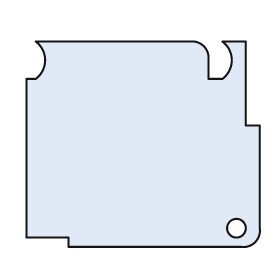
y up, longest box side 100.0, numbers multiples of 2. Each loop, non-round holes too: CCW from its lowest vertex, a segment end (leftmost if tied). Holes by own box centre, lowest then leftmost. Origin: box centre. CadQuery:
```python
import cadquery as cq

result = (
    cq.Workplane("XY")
    .moveTo(-32.0, -44.0)
    .lineTo(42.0, -44.0)
    .threePointArc((48.0, -42.0), (50.0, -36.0))
    .lineTo(50.0, 8.0)
    .lineTo(44.0, 8.0)
    .lineTo(44.0, 44.0)
    .lineTo(34.0, 44.0)
    .threePointArc((38.0, 36.0), (34.0, 28.0))
    .lineTo(28.0, 28.0)
    .lineTo(28.0, 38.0)
    .threePointArc((26.0, 42.0), (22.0, 44.0))
    .lineTo(-46.0, 44.0)
    .threePointArc((-42.0, 36.0), (-46.0, 28.0))
    .lineTo(-50.0, 28.0)
    .lineTo(-50.0, -40.0)
    .lineTo(-32.0, -40.0)
    .close()
    .moveTo(40.0, -36.0)
    .circle(4.0)
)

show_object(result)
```